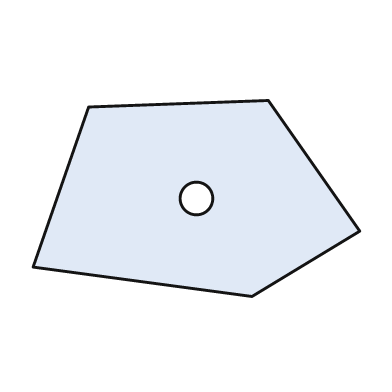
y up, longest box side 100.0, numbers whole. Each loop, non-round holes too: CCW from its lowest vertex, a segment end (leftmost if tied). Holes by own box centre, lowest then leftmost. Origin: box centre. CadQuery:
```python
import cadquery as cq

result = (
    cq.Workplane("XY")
    .moveTo(17.0, -30.0)
    .lineTo(50.0, -10.0)
    .lineTo(22.0, 30.0)
    .lineTo(-33.0, 28.0)
    .lineTo(-50.0, -21.0)
    .close()
    .moveTo(0.0, 0.0)
    .circle(5.0)
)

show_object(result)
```